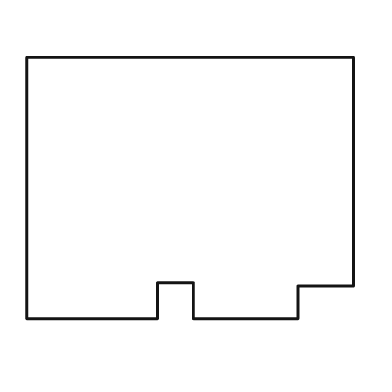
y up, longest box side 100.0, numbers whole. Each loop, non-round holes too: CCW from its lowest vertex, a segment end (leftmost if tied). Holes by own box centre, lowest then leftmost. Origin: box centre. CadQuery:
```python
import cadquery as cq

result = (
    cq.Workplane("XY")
    .moveTo(-50.0, -40.0)
    .lineTo(-10.0, -40.0)
    .lineTo(-10.0, -29.0)
    .lineTo(1.0, -29.0)
    .lineTo(1.0, -40.0)
    .lineTo(33.0, -40.0)
    .lineTo(33.0, -30.0)
    .lineTo(50.0, -30.0)
    .lineTo(50.0, 40.0)
    .lineTo(-50.0, 40.0)
    .close()
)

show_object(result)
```